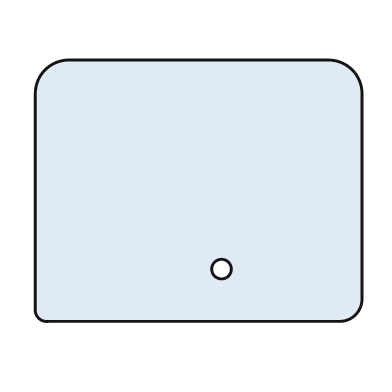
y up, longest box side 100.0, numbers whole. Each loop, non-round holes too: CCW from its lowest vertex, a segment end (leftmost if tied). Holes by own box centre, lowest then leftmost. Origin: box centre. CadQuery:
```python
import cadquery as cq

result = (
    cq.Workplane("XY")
    .moveTo(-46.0, -40.0)
    .lineTo(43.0, -40.0)
    .threePointArc((48.0, -38.0), (50.0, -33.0))
    .lineTo(50.0, 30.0)
    .threePointArc((47.0, 37.0), (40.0, 40.0))
    .lineTo(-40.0, 40.0)
    .threePointArc((-47.0, 37.0), (-50.0, 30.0))
    .lineTo(-50.0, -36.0)
    .threePointArc((-49.0, -39.0), (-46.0, -40.0))
    .close()
    .moveTo(7.0, -24.0)
    .circle(3.0)
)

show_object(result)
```